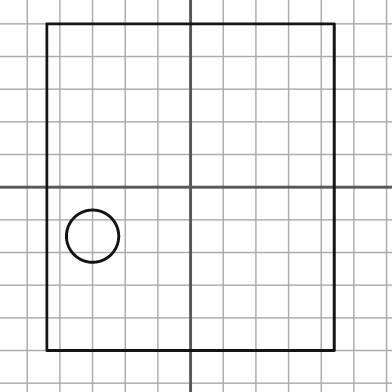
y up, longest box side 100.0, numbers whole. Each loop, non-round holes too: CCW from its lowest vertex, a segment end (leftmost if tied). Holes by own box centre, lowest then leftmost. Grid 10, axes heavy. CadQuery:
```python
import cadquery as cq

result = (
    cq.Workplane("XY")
    .moveTo(-44.0, -50.0)
    .lineTo(44.0, -50.0)
    .lineTo(44.0, 50.0)
    .lineTo(-44.0, 50.0)
    .close()
    .moveTo(-30.0, -15.0)
    .circle(8.0)
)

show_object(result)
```